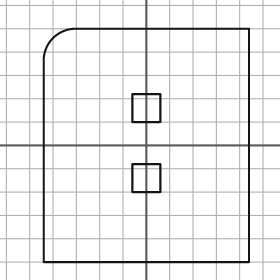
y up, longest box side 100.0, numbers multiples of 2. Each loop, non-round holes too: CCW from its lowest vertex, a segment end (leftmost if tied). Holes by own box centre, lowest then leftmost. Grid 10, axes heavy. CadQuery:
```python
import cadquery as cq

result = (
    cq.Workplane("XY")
    .moveTo(-44.0, -50.0)
    .lineTo(44.0, -50.0)
    .lineTo(44.0, 50.0)
    .lineTo(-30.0, 50.0)
    .threePointArc((-40.0, 46.0), (-44.0, 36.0))
    .close()
    .moveTo(-6.0, -20.0)
    .lineTo(6.0, -20.0)
    .lineTo(6.0, -8.0)
    .lineTo(-6.0, -8.0)
    .close()
    .moveTo(-6.0, 10.0)
    .lineTo(6.0, 10.0)
    .lineTo(6.0, 22.0)
    .lineTo(-6.0, 22.0)
    .close()
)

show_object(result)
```